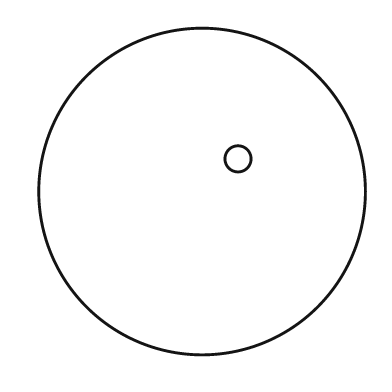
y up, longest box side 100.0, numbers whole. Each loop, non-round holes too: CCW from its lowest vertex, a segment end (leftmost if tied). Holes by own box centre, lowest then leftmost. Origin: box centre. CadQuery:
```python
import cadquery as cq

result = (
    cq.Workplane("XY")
    .moveTo(0.0, 0.0)
    .circle(50.0)
    .moveTo(11.0, 10.0)
    .circle(4.0)
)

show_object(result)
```